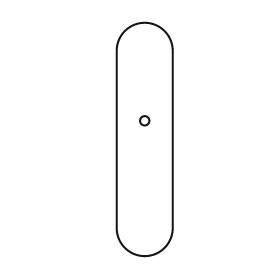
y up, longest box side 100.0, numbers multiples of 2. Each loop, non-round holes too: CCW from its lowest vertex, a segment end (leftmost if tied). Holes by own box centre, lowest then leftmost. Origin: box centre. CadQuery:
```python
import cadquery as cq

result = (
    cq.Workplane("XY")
    .moveTo(-12.0, -38.0)
    .threePointArc((0.0, -50.0), (12.0, -38.0))
    .lineTo(12.0, 38.0)
    .threePointArc((0.0, 50.0), (-12.0, 38.0))
    .close()
    .moveTo(0.0, 8.0)
    .circle(2.0)
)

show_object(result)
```